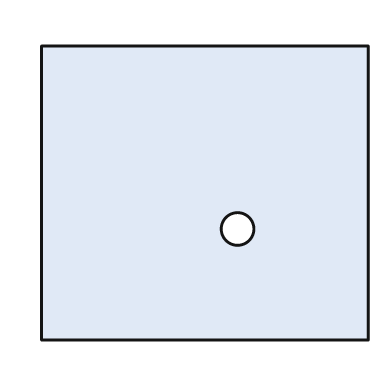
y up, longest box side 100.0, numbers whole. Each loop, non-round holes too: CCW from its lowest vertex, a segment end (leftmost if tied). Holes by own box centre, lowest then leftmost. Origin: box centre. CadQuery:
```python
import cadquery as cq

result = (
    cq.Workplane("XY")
    .moveTo(-50.0, -45.0)
    .lineTo(50.0, -45.0)
    .lineTo(50.0, 45.0)
    .lineTo(-50.0, 45.0)
    .close()
    .moveTo(10.0, -11.0)
    .circle(5.0)
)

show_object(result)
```